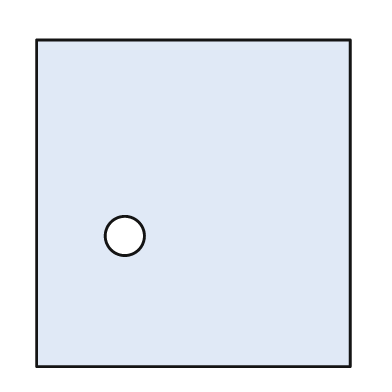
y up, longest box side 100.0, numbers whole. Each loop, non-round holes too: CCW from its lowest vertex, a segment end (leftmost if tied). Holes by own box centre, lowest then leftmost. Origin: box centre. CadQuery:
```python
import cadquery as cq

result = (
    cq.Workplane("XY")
    .moveTo(-48.0, -50.0)
    .lineTo(48.0, -50.0)
    .lineTo(48.0, 50.0)
    .lineTo(-48.0, 50.0)
    .close()
    .moveTo(-21.0, -10.0)
    .circle(6.0)
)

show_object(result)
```